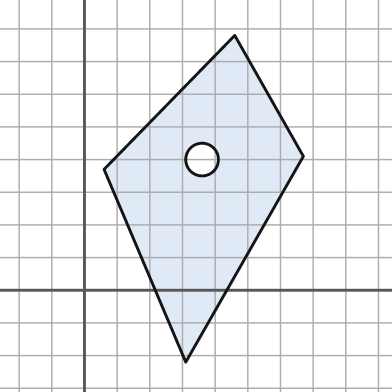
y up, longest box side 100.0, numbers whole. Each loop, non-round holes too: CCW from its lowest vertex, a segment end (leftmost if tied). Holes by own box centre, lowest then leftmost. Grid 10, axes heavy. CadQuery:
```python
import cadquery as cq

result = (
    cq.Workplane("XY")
    .moveTo(31.0, -22.0)
    .lineTo(67.0, 41.0)
    .lineTo(46.0, 78.0)
    .lineTo(6.0, 37.0)
    .close()
    .moveTo(36.0, 40.0)
    .circle(5.0)
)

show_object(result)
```